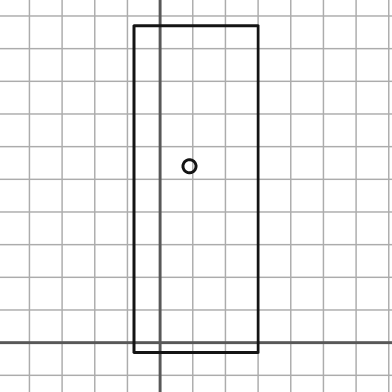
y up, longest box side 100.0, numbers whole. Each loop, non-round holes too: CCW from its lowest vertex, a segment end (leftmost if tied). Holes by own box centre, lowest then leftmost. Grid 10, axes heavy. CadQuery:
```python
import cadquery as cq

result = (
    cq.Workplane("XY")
    .moveTo(-8.0, -3.0)
    .lineTo(30.0, -3.0)
    .lineTo(30.0, 97.0)
    .lineTo(-8.0, 97.0)
    .close()
    .moveTo(9.0, 54.0)
    .circle(2.0)
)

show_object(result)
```